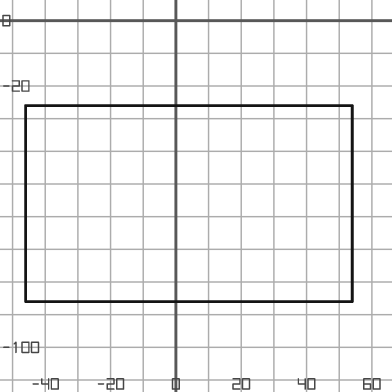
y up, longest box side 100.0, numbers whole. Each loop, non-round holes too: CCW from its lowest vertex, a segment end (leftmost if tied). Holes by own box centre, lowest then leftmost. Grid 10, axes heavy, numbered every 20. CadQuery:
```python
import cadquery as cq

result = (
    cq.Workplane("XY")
    .moveTo(-46.0, -86.0)
    .lineTo(54.0, -86.0)
    .lineTo(54.0, -26.0)
    .lineTo(-46.0, -26.0)
    .close()
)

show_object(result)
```